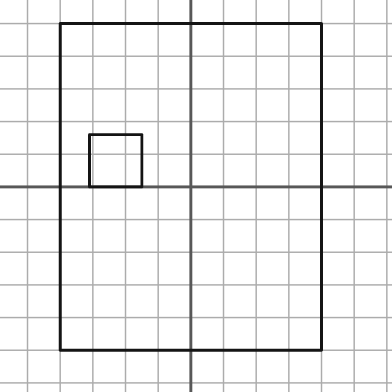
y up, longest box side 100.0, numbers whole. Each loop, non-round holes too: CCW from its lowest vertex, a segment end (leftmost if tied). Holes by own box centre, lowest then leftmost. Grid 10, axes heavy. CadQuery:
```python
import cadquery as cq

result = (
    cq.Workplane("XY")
    .moveTo(-40.0, -50.0)
    .lineTo(40.0, -50.0)
    .lineTo(40.0, 50.0)
    .lineTo(-40.0, 50.0)
    .close()
    .moveTo(-31.0, 0.0)
    .lineTo(-15.0, 0.0)
    .lineTo(-15.0, 16.0)
    .lineTo(-31.0, 16.0)
    .close()
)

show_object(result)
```